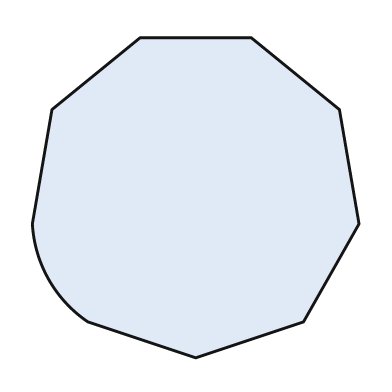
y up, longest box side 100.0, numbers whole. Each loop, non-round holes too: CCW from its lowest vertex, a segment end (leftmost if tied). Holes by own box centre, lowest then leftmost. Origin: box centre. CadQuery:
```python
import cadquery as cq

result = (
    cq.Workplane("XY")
    .moveTo(0.0, -49.0)
    .lineTo(33.0, -38.0)
    .lineTo(50.0, -8.0)
    .lineTo(44.0, 27.0)
    .lineTo(17.0, 49.0)
    .lineTo(-17.0, 49.0)
    .lineTo(-44.0, 27.0)
    .lineTo(-50.0, -8.0)
    .threePointArc((-45.0, -25.0), (-33.0, -38.0))
    .close()
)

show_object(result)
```